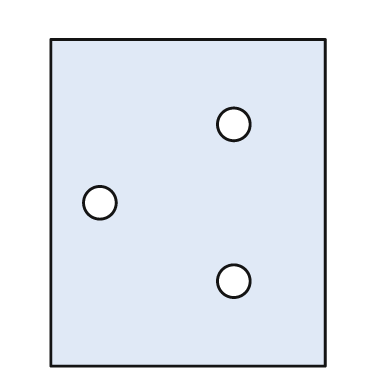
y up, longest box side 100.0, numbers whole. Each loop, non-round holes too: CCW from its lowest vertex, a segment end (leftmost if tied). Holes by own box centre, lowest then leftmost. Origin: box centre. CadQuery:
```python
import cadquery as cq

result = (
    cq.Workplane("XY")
    .moveTo(-42.0, -50.0)
    .lineTo(42.0, -50.0)
    .lineTo(42.0, 50.0)
    .lineTo(-42.0, 50.0)
    .close()
    .moveTo(14.0, -24.0)
    .circle(5.0)
    .moveTo(-27.0, 0.0)
    .circle(5.0)
    .moveTo(14.0, 24.0)
    .circle(5.0)
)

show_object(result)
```